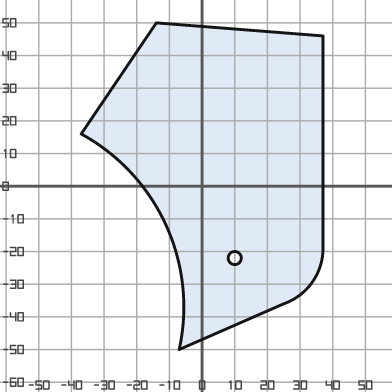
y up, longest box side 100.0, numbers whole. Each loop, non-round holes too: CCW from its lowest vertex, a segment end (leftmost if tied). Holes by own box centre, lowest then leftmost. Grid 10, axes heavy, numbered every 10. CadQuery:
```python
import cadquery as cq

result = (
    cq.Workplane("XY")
    .moveTo(-7.0, -50.0)
    .lineTo(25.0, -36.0)
    .threePointArc((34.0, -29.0), (37.0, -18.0))
    .lineTo(37.0, 46.0)
    .lineTo(-14.0, 50.0)
    .lineTo(-37.0, 16.0)
    .threePointArc((-11.0, -12.0), (-7.0, -50.0))
    .close()
    .moveTo(10.0, -22.0)
    .circle(2.0)
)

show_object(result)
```